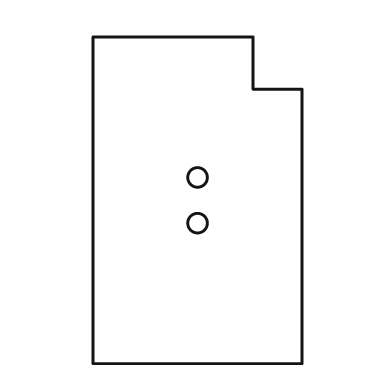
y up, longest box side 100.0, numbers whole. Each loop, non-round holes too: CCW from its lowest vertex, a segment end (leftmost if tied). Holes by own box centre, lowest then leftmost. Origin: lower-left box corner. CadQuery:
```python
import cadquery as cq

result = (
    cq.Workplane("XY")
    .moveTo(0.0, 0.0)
    .lineTo(64.0, 0.0)
    .lineTo(64.0, 84.0)
    .lineTo(49.0, 84.0)
    .lineTo(49.0, 100.0)
    .lineTo(0.0, 100.0)
    .close()
    .moveTo(32.0, 43.0)
    .circle(3.0)
    .moveTo(32.0, 57.0)
    .circle(3.0)
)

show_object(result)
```